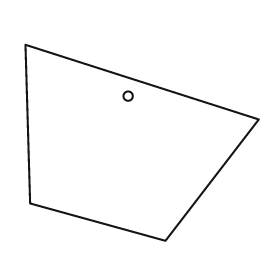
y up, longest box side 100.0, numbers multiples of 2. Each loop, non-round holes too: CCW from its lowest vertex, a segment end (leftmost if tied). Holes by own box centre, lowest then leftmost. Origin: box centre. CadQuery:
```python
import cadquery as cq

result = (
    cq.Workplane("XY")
    .moveTo(10.0, -42.0)
    .lineTo(50.0, 10.0)
    .lineTo(-50.0, 42.0)
    .lineTo(-48.0, -26.0)
    .close()
    .moveTo(-6.0, 20.0)
    .circle(2.0)
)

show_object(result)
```